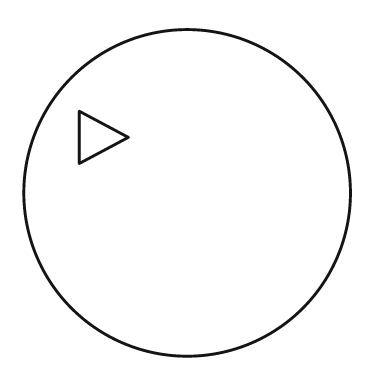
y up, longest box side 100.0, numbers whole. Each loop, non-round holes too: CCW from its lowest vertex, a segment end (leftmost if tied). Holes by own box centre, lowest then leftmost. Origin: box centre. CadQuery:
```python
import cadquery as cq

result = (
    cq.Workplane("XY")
    .moveTo(0.0, 0.0)
    .circle(50.0)
    .moveTo(-33.0, 9.0)
    .lineTo(-18.0, 17.0)
    .lineTo(-33.0, 25.0)
    .close()
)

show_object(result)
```